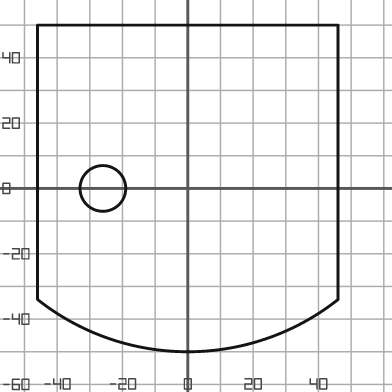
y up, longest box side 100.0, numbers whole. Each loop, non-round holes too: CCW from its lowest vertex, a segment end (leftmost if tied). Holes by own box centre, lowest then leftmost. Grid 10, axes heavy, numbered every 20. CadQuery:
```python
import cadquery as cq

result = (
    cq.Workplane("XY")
    .moveTo(-46.0, -34.0)
    .threePointArc((0.0, -50.0), (46.0, -34.0))
    .lineTo(46.0, 50.0)
    .lineTo(-46.0, 50.0)
    .close()
    .moveTo(-26.0, 0.0)
    .circle(7.0)
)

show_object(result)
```